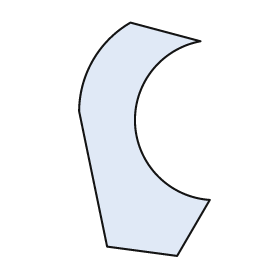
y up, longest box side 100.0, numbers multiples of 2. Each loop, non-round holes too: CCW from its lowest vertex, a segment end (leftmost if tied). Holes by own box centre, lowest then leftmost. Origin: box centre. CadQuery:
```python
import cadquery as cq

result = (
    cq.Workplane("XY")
    .moveTo(14.0, -50.0)
    .lineTo(28.0, -26.0)
    .threePointArc((-4.0, 6.0), (24.0, 42.0))
    .lineTo(-6.0, 50.0)
    .threePointArc((-22.0, 34.0), (-28.0, 12.0))
    .lineTo(-16.0, -46.0)
    .close()
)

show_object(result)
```